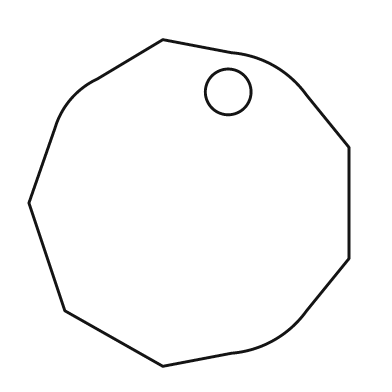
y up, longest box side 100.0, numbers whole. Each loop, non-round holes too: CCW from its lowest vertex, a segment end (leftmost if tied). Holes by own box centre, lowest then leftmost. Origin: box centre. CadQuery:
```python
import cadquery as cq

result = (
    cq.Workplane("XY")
    .moveTo(-8.0, -50.0)
    .lineTo(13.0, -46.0)
    .threePointArc((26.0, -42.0), (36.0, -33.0))
    .lineTo(49.0, -17.0)
    .lineTo(49.0, 17.0)
    .lineTo(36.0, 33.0)
    .threePointArc((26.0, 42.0), (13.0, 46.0))
    .lineTo(-8.0, 50.0)
    .lineTo(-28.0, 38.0)
    .threePointArc((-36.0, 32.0), (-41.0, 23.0))
    .lineTo(-49.0, 0.0)
    .lineTo(-38.0, -33.0)
    .close()
    .moveTo(12.0, 34.0)
    .circle(7.0)
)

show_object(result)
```